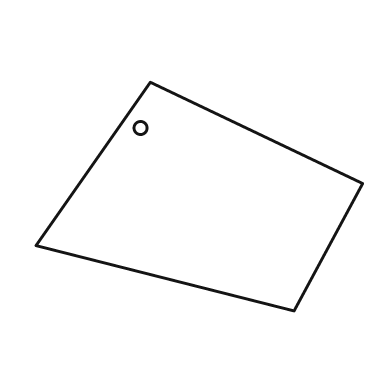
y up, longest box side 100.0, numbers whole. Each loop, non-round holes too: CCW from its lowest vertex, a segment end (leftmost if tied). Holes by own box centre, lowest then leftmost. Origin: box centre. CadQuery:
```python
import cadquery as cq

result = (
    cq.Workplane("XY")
    .moveTo(29.0, -35.0)
    .lineTo(50.0, 4.0)
    .lineTo(-15.0, 35.0)
    .lineTo(-50.0, -15.0)
    .close()
    .moveTo(-18.0, 21.0)
    .circle(2.0)
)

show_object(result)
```